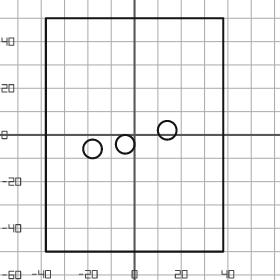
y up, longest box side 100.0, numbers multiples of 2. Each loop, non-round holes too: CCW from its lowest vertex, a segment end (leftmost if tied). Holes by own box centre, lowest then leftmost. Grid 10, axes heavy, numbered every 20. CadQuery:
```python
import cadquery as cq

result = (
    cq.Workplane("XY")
    .moveTo(-38.0, -50.0)
    .lineTo(38.0, -50.0)
    .lineTo(38.0, 50.0)
    .lineTo(-38.0, 50.0)
    .close()
    .moveTo(-18.0, -6.0)
    .circle(4.0)
    .moveTo(-4.0, -4.0)
    .circle(4.0)
    .moveTo(14.0, 2.0)
    .circle(4.0)
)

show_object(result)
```